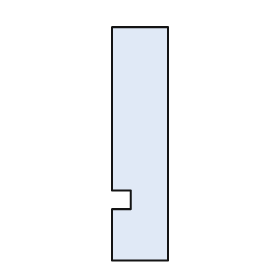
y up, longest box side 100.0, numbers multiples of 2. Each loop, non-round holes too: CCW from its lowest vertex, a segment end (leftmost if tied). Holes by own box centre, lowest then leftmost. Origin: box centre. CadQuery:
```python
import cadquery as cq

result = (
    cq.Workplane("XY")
    .moveTo(-12.0, -50.0)
    .lineTo(12.0, -50.0)
    .lineTo(12.0, 50.0)
    .lineTo(-12.0, 50.0)
    .lineTo(-12.0, -20.0)
    .lineTo(-4.0, -20.0)
    .lineTo(-4.0, -28.0)
    .lineTo(-12.0, -28.0)
    .close()
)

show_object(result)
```